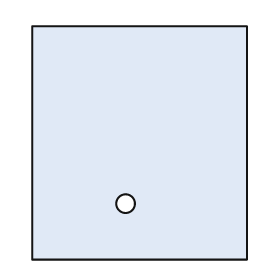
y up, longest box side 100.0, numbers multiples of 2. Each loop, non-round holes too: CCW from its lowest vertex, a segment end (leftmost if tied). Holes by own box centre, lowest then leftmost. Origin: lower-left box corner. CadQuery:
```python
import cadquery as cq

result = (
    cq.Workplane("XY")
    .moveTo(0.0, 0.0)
    .lineTo(92.0, 0.0)
    .lineTo(92.0, 100.0)
    .lineTo(0.0, 100.0)
    .close()
    .moveTo(40.0, 24.0)
    .circle(4.0)
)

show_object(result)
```